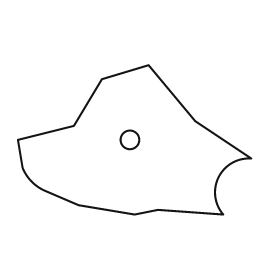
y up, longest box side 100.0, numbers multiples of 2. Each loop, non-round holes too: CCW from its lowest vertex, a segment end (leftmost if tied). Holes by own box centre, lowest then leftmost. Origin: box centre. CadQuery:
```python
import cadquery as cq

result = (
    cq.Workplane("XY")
    .moveTo(0.0, -32.0)
    .lineTo(10.0, -30.0)
    .lineTo(38.0, -32.0)
    .threePointArc((36.0, -16.0), (50.0, -8.0))
    .lineTo(26.0, 8.0)
    .lineTo(6.0, 32.0)
    .lineTo(-14.0, 26.0)
    .lineTo(-26.0, 6.0)
    .lineTo(-50.0, 0.0)
    .lineTo(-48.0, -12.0)
    .threePointArc((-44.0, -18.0), (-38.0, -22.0))
    .lineTo(-24.0, -28.0)
    .close()
    .moveTo(-2.0, 0.0)
    .circle(4.0)
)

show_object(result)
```